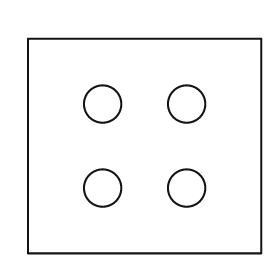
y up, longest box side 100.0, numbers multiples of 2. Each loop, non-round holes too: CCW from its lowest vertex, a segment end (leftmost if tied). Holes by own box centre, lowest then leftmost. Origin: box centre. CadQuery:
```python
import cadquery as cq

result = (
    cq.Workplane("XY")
    .moveTo(-50.0, -46.0)
    .lineTo(50.0, -46.0)
    .lineTo(50.0, 46.0)
    .lineTo(-50.0, 46.0)
    .close()
    .moveTo(-18.0, -18.0)
    .circle(8.0)
    .moveTo(18.0, -18.0)
    .circle(8.0)
    .moveTo(-18.0, 18.0)
    .circle(8.0)
    .moveTo(18.0, 18.0)
    .circle(8.0)
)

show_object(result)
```